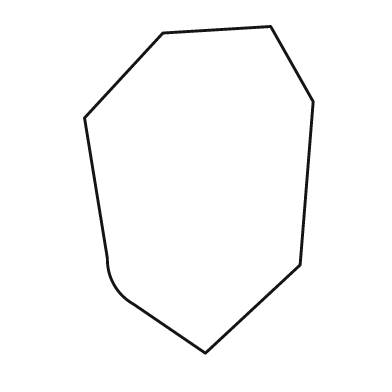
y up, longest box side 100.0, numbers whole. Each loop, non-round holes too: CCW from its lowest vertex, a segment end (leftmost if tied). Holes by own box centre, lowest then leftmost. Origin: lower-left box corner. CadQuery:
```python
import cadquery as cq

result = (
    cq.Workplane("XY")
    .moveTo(37.0, 0.0)
    .lineTo(66.0, 27.0)
    .lineTo(70.0, 77.0)
    .lineTo(57.0, 100.0)
    .lineTo(24.0, 98.0)
    .lineTo(0.0, 72.0)
    .lineTo(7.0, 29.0)
    .threePointArc((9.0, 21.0), (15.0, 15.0))
    .close()
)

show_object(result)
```